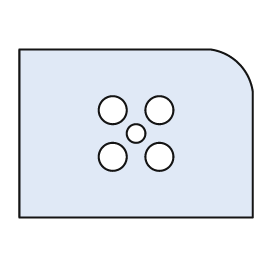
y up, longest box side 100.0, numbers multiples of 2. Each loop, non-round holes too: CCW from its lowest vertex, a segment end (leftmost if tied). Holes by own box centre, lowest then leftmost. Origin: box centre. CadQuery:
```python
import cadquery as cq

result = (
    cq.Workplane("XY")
    .moveTo(-50.0, -36.0)
    .lineTo(50.0, -36.0)
    .lineTo(50.0, 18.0)
    .threePointArc((44.0, 30.0), (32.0, 36.0))
    .lineTo(-50.0, 36.0)
    .close()
    .moveTo(-10.0, -10.0)
    .circle(6.0)
    .moveTo(10.0, -10.0)
    .circle(6.0)
    .moveTo(0.0, 0.0)
    .circle(4.0)
    .moveTo(-10.0, 10.0)
    .circle(6.0)
    .moveTo(10.0, 10.0)
    .circle(6.0)
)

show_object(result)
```